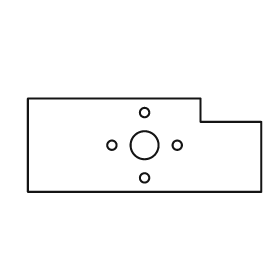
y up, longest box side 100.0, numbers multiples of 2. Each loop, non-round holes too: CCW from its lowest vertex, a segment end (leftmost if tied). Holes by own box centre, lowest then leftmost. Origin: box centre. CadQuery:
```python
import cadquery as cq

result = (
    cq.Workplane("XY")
    .moveTo(-50.0, -20.0)
    .lineTo(50.0, -20.0)
    .lineTo(50.0, 10.0)
    .lineTo(24.0, 10.0)
    .lineTo(24.0, 20.0)
    .lineTo(-50.0, 20.0)
    .close()
    .moveTo(0.0, -14.0)
    .circle(2.0)
    .moveTo(-14.0, 0.0)
    .circle(2.0)
    .moveTo(0.0, 0.0)
    .circle(6.0)
    .moveTo(14.0, 0.0)
    .circle(2.0)
    .moveTo(0.0, 14.0)
    .circle(2.0)
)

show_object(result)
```